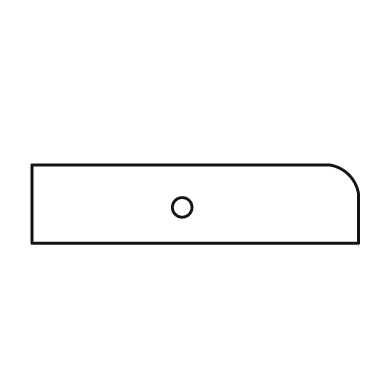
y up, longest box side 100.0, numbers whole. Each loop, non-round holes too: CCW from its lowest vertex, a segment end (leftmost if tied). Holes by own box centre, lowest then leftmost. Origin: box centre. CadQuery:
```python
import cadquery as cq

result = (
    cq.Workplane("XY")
    .moveTo(-50.0, -12.0)
    .lineTo(50.0, -12.0)
    .lineTo(50.0, 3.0)
    .threePointArc((47.0, 9.0), (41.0, 12.0))
    .lineTo(-50.0, 12.0)
    .close()
    .moveTo(-4.0, -1.0)
    .circle(3.0)
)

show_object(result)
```